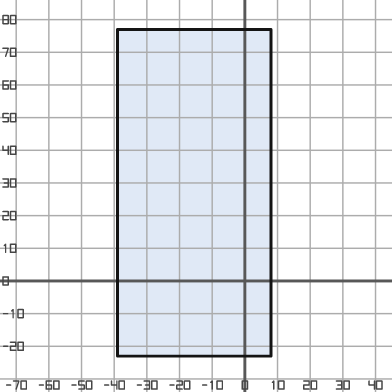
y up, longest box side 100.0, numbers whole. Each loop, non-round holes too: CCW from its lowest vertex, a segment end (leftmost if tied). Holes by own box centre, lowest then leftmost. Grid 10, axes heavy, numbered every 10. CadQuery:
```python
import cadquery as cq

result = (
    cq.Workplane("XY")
    .moveTo(-39.0, -23.0)
    .lineTo(8.0, -23.0)
    .lineTo(8.0, 77.0)
    .lineTo(-39.0, 77.0)
    .close()
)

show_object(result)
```